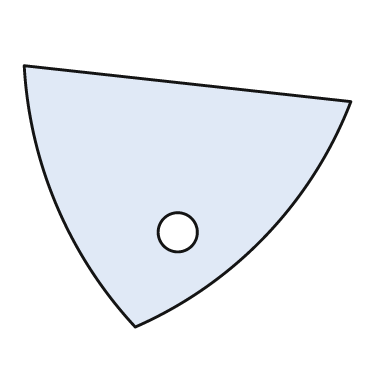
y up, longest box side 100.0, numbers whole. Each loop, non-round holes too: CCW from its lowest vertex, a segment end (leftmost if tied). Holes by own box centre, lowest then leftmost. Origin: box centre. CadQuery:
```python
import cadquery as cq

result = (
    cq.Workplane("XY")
    .moveTo(-16.0, -40.0)
    .threePointArc((24.0, -12.0), (50.0, 29.0))
    .lineTo(-50.0, 40.0)
    .threePointArc((-40.0, -3.0), (-16.0, -40.0))
    .close()
    .moveTo(-3.0, -11.0)
    .circle(6.0)
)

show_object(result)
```